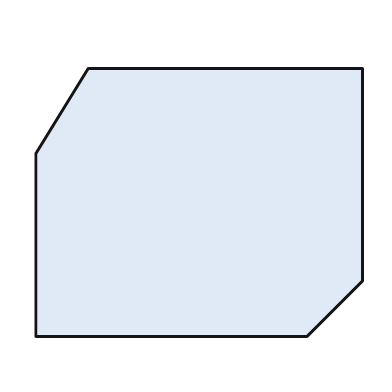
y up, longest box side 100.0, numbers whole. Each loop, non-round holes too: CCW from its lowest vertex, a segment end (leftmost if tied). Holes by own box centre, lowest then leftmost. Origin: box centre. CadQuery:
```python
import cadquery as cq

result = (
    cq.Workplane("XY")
    .moveTo(-50.0, -41.0)
    .lineTo(33.0, -41.0)
    .lineTo(50.0, -24.0)
    .lineTo(50.0, 41.0)
    .lineTo(-34.0, 41.0)
    .lineTo(-50.0, 15.0)
    .close()
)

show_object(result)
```